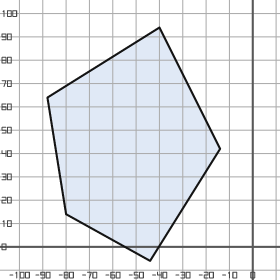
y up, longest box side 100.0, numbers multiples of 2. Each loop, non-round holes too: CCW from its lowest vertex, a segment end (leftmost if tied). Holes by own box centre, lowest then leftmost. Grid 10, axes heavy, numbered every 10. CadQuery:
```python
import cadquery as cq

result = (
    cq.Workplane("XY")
    .moveTo(-44.0, -6.0)
    .lineTo(-14.0, 42.0)
    .lineTo(-40.0, 94.0)
    .lineTo(-88.0, 64.0)
    .lineTo(-80.0, 14.0)
    .close()
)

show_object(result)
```